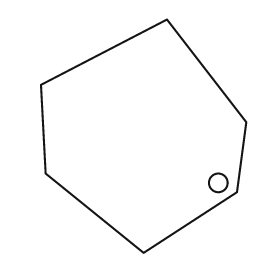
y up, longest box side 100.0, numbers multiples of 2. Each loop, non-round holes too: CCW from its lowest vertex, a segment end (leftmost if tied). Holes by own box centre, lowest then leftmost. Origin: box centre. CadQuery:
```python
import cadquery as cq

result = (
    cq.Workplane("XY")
    .moveTo(0.0, -50.0)
    .lineTo(40.0, -24.0)
    .lineTo(44.0, 6.0)
    .lineTo(10.0, 50.0)
    .lineTo(-44.0, 22.0)
    .lineTo(-42.0, -16.0)
    .close()
    .moveTo(32.0, -20.0)
    .circle(4.0)
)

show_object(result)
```